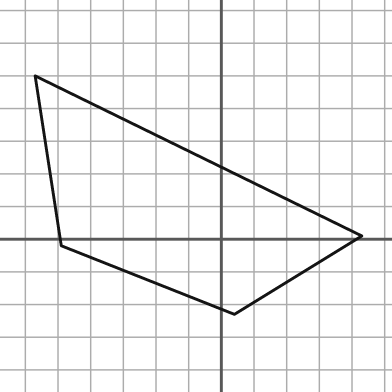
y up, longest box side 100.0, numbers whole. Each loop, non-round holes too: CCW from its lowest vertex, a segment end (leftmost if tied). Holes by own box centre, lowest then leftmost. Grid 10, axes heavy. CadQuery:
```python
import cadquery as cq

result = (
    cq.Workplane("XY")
    .moveTo(4.0, -23.0)
    .lineTo(43.0, 1.0)
    .lineTo(-57.0, 50.0)
    .lineTo(-49.0, -2.0)
    .close()
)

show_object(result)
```